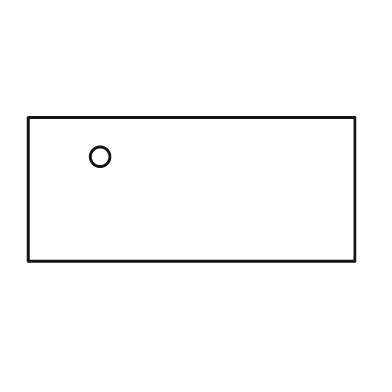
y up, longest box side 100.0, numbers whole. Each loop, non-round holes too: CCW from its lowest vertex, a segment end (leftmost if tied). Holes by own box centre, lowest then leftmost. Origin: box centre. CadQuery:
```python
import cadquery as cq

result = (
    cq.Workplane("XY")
    .moveTo(-50.0, -22.0)
    .lineTo(50.0, -22.0)
    .lineTo(50.0, 22.0)
    .lineTo(-50.0, 22.0)
    .close()
    .moveTo(-28.0, 10.0)
    .circle(3.0)
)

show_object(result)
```